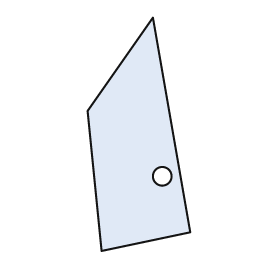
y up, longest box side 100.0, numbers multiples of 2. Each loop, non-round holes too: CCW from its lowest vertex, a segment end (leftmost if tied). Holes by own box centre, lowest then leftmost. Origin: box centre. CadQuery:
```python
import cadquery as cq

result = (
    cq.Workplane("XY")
    .moveTo(-16.0, -50.0)
    .lineTo(22.0, -42.0)
    .lineTo(6.0, 50.0)
    .lineTo(-22.0, 10.0)
    .close()
    .moveTo(10.0, -18.0)
    .circle(4.0)
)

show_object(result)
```